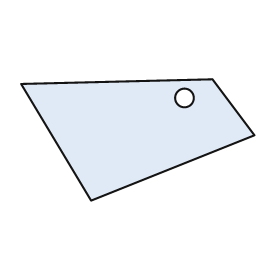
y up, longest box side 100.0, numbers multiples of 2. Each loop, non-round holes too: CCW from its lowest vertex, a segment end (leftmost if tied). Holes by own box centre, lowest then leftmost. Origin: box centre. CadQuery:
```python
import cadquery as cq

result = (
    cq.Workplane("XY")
    .moveTo(-20.0, -26.0)
    .lineTo(50.0, 2.0)
    .lineTo(32.0, 26.0)
    .lineTo(-50.0, 24.0)
    .close()
    .moveTo(20.0, 18.0)
    .circle(4.0)
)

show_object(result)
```